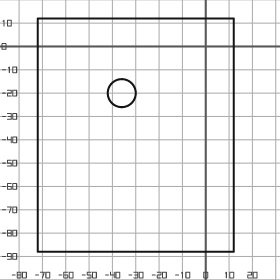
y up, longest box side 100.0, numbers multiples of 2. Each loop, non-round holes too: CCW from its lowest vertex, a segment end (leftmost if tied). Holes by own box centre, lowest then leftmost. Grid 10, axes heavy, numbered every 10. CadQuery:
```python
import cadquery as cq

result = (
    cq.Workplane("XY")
    .moveTo(-72.0, -88.0)
    .lineTo(12.0, -88.0)
    .lineTo(12.0, 12.0)
    .lineTo(-72.0, 12.0)
    .close()
    .moveTo(-36.0, -20.0)
    .circle(6.0)
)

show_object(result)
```